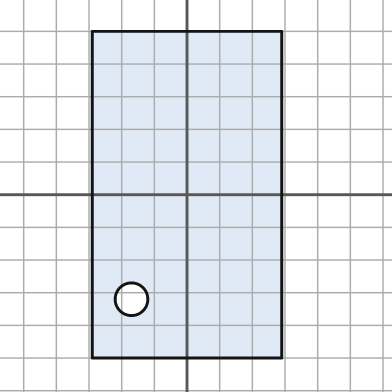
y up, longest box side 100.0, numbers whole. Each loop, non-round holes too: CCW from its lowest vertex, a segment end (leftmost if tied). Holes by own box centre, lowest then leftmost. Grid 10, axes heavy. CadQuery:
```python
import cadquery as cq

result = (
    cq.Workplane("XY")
    .moveTo(-29.0, -50.0)
    .lineTo(29.0, -50.0)
    .lineTo(29.0, 50.0)
    .lineTo(-29.0, 50.0)
    .close()
    .moveTo(-17.0, -32.0)
    .circle(5.0)
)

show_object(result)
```